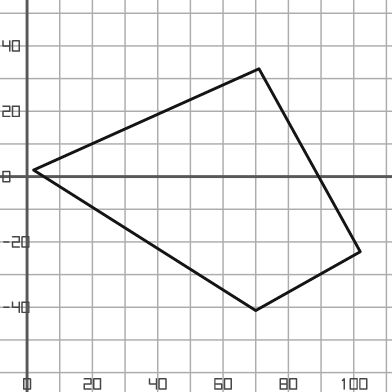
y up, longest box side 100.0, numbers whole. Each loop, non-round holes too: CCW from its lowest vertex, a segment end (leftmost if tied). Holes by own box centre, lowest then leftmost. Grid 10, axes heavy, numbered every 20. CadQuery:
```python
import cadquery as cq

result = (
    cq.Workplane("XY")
    .moveTo(70.0, -41.0)
    .lineTo(102.0, -23.0)
    .lineTo(71.0, 33.0)
    .lineTo(2.0, 2.0)
    .close()
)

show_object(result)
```